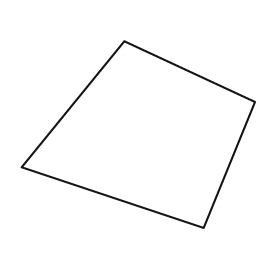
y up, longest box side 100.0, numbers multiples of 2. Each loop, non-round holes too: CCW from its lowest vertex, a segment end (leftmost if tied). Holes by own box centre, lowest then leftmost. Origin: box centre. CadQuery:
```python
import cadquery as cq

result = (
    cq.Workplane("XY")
    .moveTo(28.0, -40.0)
    .lineTo(50.0, 14.0)
    .lineTo(-6.0, 40.0)
    .lineTo(-50.0, -14.0)
    .close()
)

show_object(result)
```